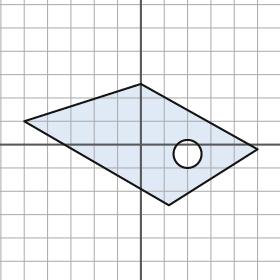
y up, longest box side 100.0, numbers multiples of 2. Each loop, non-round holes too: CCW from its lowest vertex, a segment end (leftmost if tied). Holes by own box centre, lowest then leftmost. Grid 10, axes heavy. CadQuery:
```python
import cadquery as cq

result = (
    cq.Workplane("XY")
    .moveTo(12.0, -26.0)
    .lineTo(50.0, -2.0)
    .lineTo(0.0, 26.0)
    .lineTo(-50.0, 10.0)
    .close()
    .moveTo(20.0, -4.0)
    .circle(6.0)
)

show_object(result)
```